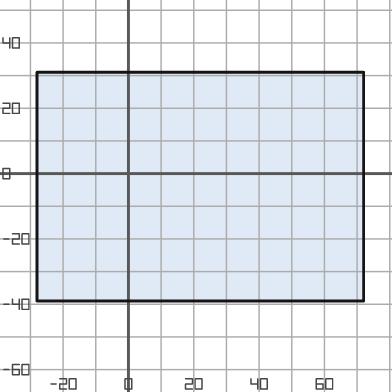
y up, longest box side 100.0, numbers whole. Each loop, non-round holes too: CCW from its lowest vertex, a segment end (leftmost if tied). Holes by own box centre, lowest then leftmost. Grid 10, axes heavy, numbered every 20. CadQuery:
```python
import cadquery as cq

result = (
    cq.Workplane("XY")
    .moveTo(-28.0, -39.0)
    .lineTo(72.0, -39.0)
    .lineTo(72.0, 31.0)
    .lineTo(-28.0, 31.0)
    .close()
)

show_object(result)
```